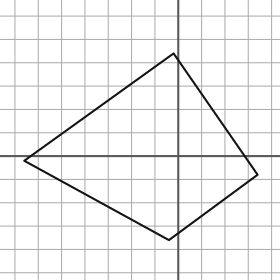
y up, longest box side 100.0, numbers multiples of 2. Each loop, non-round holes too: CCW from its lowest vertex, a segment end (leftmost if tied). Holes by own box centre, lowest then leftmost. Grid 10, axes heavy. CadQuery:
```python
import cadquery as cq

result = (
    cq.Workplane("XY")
    .moveTo(-4.0, -36.0)
    .lineTo(34.0, -8.0)
    .lineTo(-2.0, 44.0)
    .lineTo(-66.0, -2.0)
    .close()
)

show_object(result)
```